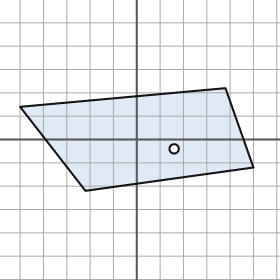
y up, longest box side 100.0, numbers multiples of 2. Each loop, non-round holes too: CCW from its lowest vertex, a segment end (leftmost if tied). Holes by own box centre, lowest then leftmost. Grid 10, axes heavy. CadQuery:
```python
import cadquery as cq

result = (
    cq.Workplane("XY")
    .moveTo(-22.0, -22.0)
    .lineTo(50.0, -12.0)
    .lineTo(38.0, 22.0)
    .lineTo(-50.0, 14.0)
    .close()
    .moveTo(16.0, -4.0)
    .circle(2.0)
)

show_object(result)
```